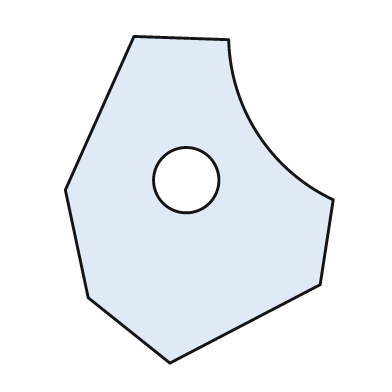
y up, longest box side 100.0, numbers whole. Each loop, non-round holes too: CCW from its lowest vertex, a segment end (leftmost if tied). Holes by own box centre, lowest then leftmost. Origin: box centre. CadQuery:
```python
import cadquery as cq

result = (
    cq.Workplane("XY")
    .moveTo(-9.0, -50.0)
    .lineTo(37.0, -26.0)
    .lineTo(41.0, 0.0)
    .threePointArc((18.0, 20.0), (9.0, 49.0))
    .lineTo(-20.0, 50.0)
    .lineTo(-41.0, 3.0)
    .lineTo(-34.0, -30.0)
    .close()
    .moveTo(-4.0, 6.0)
    .circle(10.0)
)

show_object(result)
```